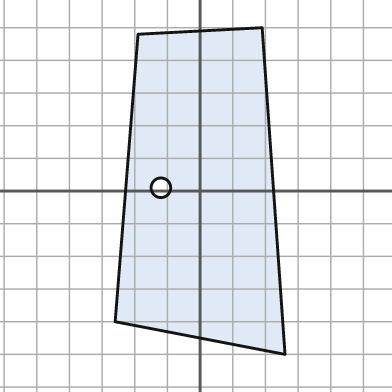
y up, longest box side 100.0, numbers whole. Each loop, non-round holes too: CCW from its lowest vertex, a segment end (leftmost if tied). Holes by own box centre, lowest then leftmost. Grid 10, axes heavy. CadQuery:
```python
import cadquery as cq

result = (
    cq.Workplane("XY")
    .moveTo(26.0, -50.0)
    .lineTo(19.0, 50.0)
    .lineTo(-19.0, 48.0)
    .lineTo(-26.0, -40.0)
    .close()
    .moveTo(-12.0, 1.0)
    .circle(3.0)
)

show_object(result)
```